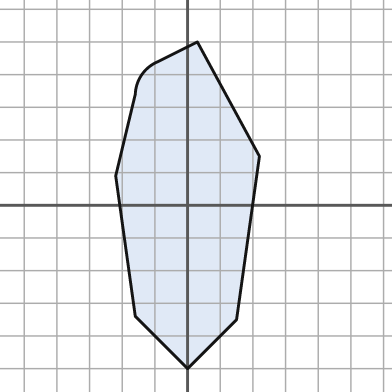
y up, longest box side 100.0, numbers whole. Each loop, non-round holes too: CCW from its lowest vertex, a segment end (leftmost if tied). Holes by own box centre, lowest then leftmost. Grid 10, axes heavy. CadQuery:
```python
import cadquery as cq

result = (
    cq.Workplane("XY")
    .moveTo(0.0, -50.0)
    .lineTo(15.0, -35.0)
    .lineTo(22.0, 15.0)
    .lineTo(3.0, 50.0)
    .lineTo(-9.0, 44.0)
    .threePointArc((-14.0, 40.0), (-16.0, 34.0))
    .lineTo(-22.0, 9.0)
    .lineTo(-16.0, -34.0)
    .close()
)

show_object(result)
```